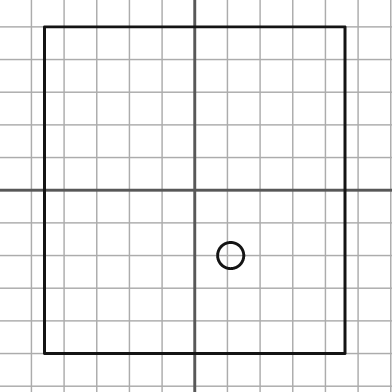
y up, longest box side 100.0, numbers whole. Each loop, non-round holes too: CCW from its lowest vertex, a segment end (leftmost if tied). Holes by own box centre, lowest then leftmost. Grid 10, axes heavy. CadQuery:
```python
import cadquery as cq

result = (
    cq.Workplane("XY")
    .moveTo(-46.0, -50.0)
    .lineTo(46.0, -50.0)
    .lineTo(46.0, 50.0)
    .lineTo(-46.0, 50.0)
    .close()
    .moveTo(11.0, -20.0)
    .circle(4.0)
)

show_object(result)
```